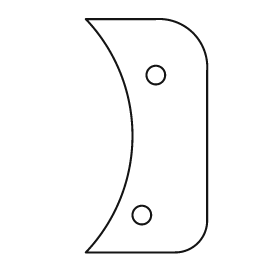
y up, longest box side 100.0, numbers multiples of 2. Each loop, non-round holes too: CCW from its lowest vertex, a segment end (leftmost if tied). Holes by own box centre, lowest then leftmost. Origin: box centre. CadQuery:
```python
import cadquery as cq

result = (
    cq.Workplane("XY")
    .moveTo(-26.0, -50.0)
    .lineTo(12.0, -50.0)
    .threePointArc((22.0, -46.0), (26.0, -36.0))
    .lineTo(26.0, 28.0)
    .threePointArc((20.0, 44.0), (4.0, 50.0))
    .lineTo(-26.0, 50.0)
    .threePointArc((-6.0, 0.0), (-26.0, -50.0))
    .close()
    .moveTo(-2.0, -34.0)
    .circle(4.0)
    .moveTo(4.0, 26.0)
    .circle(4.0)
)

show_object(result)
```